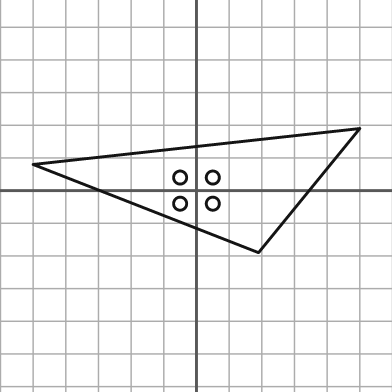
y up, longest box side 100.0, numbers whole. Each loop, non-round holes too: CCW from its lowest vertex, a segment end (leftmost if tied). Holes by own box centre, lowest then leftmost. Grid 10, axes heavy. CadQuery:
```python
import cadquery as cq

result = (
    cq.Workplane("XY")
    .moveTo(19.0, -19.0)
    .lineTo(50.0, 19.0)
    .lineTo(-50.0, 8.0)
    .close()
    .moveTo(-5.0, -4.0)
    .circle(2.0)
    .moveTo(5.0, -4.0)
    .circle(2.0)
    .moveTo(-5.0, 4.0)
    .circle(2.0)
    .moveTo(5.0, 4.0)
    .circle(2.0)
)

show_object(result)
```